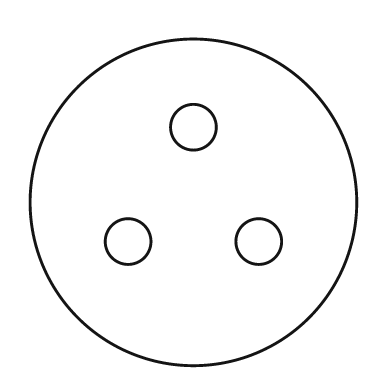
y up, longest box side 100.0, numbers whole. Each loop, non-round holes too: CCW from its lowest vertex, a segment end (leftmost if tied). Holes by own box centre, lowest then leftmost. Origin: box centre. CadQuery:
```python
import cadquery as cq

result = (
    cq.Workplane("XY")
    .moveTo(0.0, 0.0)
    .circle(50.0)
    .moveTo(-20.0, -12.0)
    .circle(7.0)
    .moveTo(20.0, -12.0)
    .circle(7.0)
    .moveTo(0.0, 23.0)
    .circle(7.0)
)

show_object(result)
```